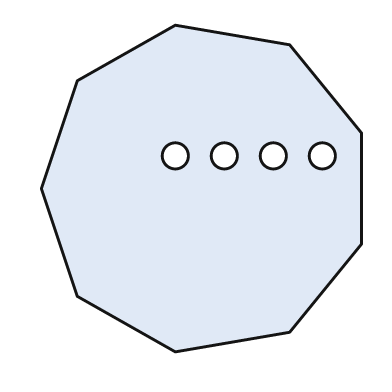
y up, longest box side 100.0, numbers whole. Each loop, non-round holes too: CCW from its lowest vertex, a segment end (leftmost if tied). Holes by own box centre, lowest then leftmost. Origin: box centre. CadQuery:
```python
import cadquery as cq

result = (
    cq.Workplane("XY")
    .moveTo(-8.0, -50.0)
    .lineTo(27.0, -44.0)
    .lineTo(49.0, -17.0)
    .lineTo(49.0, 17.0)
    .lineTo(27.0, 44.0)
    .lineTo(-8.0, 50.0)
    .lineTo(-38.0, 33.0)
    .lineTo(-49.0, 0.0)
    .lineTo(-38.0, -33.0)
    .close()
    .moveTo(-8.0, 10.0)
    .circle(4.0)
    .moveTo(7.0, 10.0)
    .circle(4.0)
    .moveTo(22.0, 10.0)
    .circle(4.0)
    .moveTo(37.0, 10.0)
    .circle(4.0)
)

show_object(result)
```